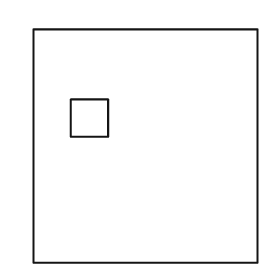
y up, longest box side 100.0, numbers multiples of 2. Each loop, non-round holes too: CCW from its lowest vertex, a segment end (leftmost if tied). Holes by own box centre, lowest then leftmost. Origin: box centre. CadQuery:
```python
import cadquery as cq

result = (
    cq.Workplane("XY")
    .moveTo(-48.0, -50.0)
    .lineTo(48.0, -50.0)
    .lineTo(48.0, 50.0)
    .lineTo(-48.0, 50.0)
    .close()
    .moveTo(-32.0, 4.0)
    .lineTo(-16.0, 4.0)
    .lineTo(-16.0, 20.0)
    .lineTo(-32.0, 20.0)
    .close()
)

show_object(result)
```